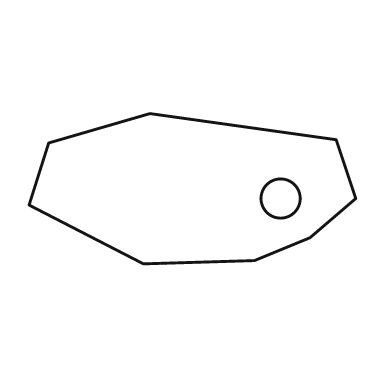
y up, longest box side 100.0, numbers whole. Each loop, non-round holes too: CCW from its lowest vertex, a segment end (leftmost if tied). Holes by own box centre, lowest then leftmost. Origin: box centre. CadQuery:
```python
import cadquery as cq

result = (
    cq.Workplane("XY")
    .moveTo(-15.0, -23.0)
    .lineTo(19.0, -22.0)
    .lineTo(36.0, -15.0)
    .lineTo(50.0, -3.0)
    .lineTo(44.0, 15.0)
    .lineTo(-13.0, 23.0)
    .lineTo(-44.0, 14.0)
    .lineTo(-50.0, -5.0)
    .close()
    .moveTo(27.0, -3.0)
    .circle(6.0)
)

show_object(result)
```